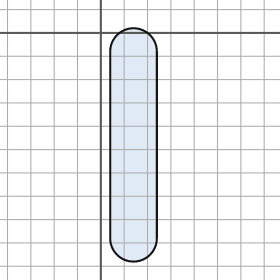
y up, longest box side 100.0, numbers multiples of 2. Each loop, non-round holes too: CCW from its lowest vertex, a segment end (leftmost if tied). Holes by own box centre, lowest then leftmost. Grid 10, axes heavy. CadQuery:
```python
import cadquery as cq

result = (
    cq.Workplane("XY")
    .moveTo(4.0, -88.0)
    .threePointArc((14.0, -98.0), (24.0, -88.0))
    .lineTo(24.0, -8.0)
    .threePointArc((14.0, 2.0), (4.0, -8.0))
    .close()
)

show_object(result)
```